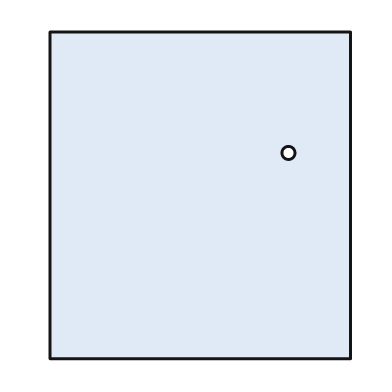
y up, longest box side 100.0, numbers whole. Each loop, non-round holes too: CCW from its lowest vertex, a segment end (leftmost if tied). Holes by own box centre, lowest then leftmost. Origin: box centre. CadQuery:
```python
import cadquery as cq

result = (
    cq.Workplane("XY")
    .moveTo(-46.0, -50.0)
    .lineTo(46.0, -50.0)
    .lineTo(46.0, 50.0)
    .lineTo(-46.0, 50.0)
    .close()
    .moveTo(27.0, 13.0)
    .circle(2.0)
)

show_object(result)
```